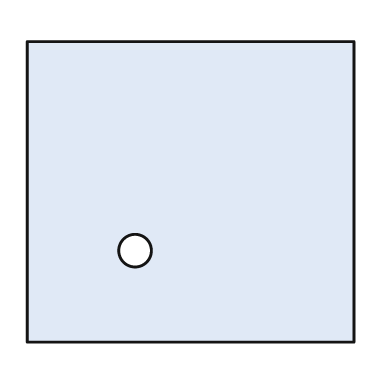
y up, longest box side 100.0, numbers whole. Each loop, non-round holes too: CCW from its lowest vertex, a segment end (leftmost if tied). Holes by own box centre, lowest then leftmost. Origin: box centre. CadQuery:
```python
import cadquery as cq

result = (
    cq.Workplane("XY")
    .moveTo(-50.0, -46.0)
    .lineTo(50.0, -46.0)
    .lineTo(50.0, 46.0)
    .lineTo(-50.0, 46.0)
    .close()
    .moveTo(-17.0, -18.0)
    .circle(5.0)
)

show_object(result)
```